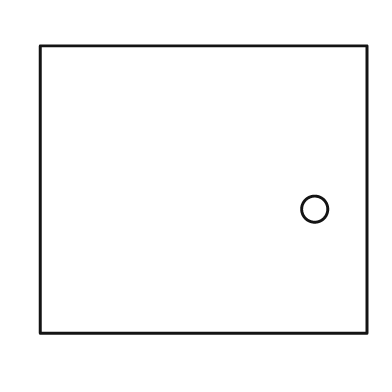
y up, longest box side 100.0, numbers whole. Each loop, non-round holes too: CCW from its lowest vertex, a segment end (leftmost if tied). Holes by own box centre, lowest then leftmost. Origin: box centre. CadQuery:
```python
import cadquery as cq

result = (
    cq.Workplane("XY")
    .moveTo(-50.0, -44.0)
    .lineTo(50.0, -44.0)
    .lineTo(50.0, 44.0)
    .lineTo(-50.0, 44.0)
    .close()
    .moveTo(34.0, -6.0)
    .circle(4.0)
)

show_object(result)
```